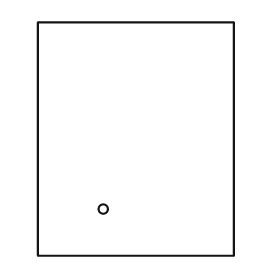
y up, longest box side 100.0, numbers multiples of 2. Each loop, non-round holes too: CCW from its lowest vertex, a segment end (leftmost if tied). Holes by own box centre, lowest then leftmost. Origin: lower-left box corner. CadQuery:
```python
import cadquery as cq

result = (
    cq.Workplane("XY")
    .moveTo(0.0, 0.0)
    .lineTo(84.0, 0.0)
    .lineTo(84.0, 100.0)
    .lineTo(0.0, 100.0)
    .close()
    .moveTo(28.0, 20.0)
    .circle(2.0)
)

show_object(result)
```